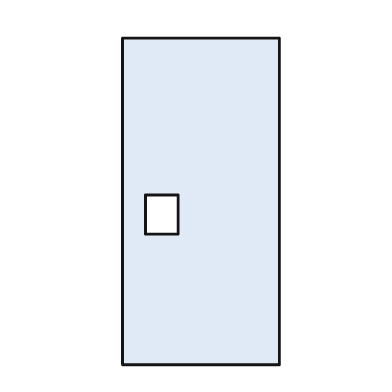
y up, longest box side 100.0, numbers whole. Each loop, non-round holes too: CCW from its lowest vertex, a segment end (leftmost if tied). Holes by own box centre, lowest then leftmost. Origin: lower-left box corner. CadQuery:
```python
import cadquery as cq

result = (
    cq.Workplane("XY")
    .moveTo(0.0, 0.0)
    .lineTo(48.0, 0.0)
    .lineTo(48.0, 100.0)
    .lineTo(0.0, 100.0)
    .close()
    .moveTo(7.0, 40.0)
    .lineTo(17.0, 40.0)
    .lineTo(17.0, 52.0)
    .lineTo(7.0, 52.0)
    .close()
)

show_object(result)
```